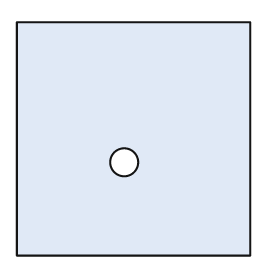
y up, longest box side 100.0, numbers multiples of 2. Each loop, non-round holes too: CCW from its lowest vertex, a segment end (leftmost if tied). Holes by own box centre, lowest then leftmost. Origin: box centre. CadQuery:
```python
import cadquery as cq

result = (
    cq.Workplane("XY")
    .moveTo(-50.0, -50.0)
    .lineTo(50.0, -50.0)
    .lineTo(50.0, 50.0)
    .lineTo(-50.0, 50.0)
    .close()
    .moveTo(-4.0, -10.0)
    .circle(6.0)
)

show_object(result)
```